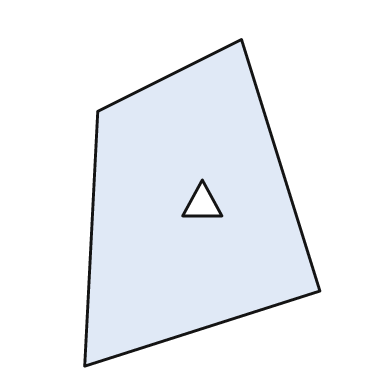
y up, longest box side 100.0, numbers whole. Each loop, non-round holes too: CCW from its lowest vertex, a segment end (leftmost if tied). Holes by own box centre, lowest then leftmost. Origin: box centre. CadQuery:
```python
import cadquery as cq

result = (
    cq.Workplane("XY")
    .moveTo(-36.0, -50.0)
    .lineTo(36.0, -27.0)
    .lineTo(12.0, 50.0)
    .lineTo(-32.0, 28.0)
    .close()
    .moveTo(-6.0, -4.0)
    .lineTo(6.0, -4.0)
    .lineTo(0.0, 7.0)
    .close()
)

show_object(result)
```